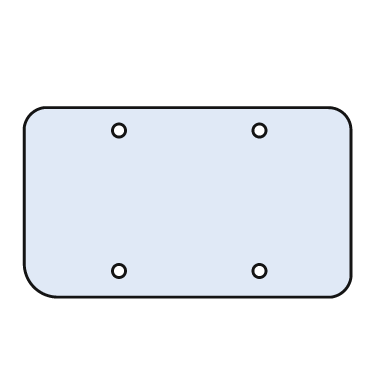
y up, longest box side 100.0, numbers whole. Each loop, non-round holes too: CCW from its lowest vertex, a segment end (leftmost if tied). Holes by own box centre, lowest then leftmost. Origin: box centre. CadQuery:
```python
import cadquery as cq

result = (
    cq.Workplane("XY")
    .moveTo(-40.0, -29.0)
    .lineTo(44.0, -29.0)
    .threePointArc((48.0, -27.0), (50.0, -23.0))
    .lineTo(50.0, 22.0)
    .threePointArc((48.0, 27.0), (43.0, 29.0))
    .lineTo(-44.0, 29.0)
    .threePointArc((-48.0, 27.0), (-50.0, 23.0))
    .lineTo(-50.0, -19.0)
    .threePointArc((-47.0, -26.0), (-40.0, -29.0))
    .close()
    .moveTo(-21.0, -21.0)
    .circle(2.0)
    .moveTo(22.0, -21.0)
    .circle(2.0)
    .moveTo(-21.0, 22.0)
    .circle(2.0)
    .moveTo(22.0, 22.0)
    .circle(2.0)
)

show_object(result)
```